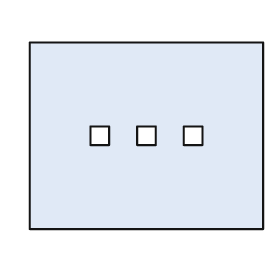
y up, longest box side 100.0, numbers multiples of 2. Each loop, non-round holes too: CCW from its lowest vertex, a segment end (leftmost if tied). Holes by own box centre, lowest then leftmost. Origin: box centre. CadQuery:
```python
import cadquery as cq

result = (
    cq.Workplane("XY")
    .moveTo(-50.0, -40.0)
    .lineTo(50.0, -40.0)
    .lineTo(50.0, 40.0)
    .lineTo(-50.0, 40.0)
    .close()
    .moveTo(-24.0, -4.0)
    .lineTo(-16.0, -4.0)
    .lineTo(-16.0, 4.0)
    .lineTo(-24.0, 4.0)
    .close()
    .moveTo(-4.0, -4.0)
    .lineTo(4.0, -4.0)
    .lineTo(4.0, 4.0)
    .lineTo(-4.0, 4.0)
    .close()
    .moveTo(16.0, -4.0)
    .lineTo(24.0, -4.0)
    .lineTo(24.0, 4.0)
    .lineTo(16.0, 4.0)
    .close()
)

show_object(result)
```